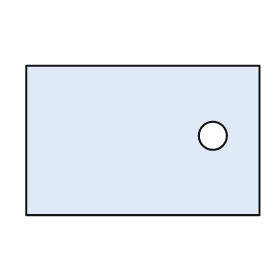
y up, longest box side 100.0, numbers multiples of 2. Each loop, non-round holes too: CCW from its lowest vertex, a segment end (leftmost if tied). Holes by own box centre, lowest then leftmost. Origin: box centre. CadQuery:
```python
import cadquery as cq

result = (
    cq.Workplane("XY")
    .moveTo(-50.0, -32.0)
    .lineTo(50.0, -32.0)
    .lineTo(50.0, 32.0)
    .lineTo(-50.0, 32.0)
    .close()
    .moveTo(30.0, 2.0)
    .circle(6.0)
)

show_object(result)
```